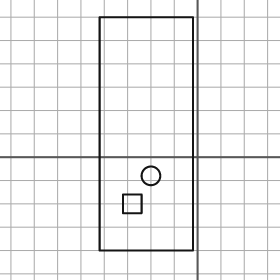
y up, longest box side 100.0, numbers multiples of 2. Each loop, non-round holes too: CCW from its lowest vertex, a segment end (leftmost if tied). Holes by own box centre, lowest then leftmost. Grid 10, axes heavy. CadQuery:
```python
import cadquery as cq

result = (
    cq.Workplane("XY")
    .moveTo(-42.0, -40.0)
    .lineTo(-2.0, -40.0)
    .lineTo(-2.0, 60.0)
    .lineTo(-42.0, 60.0)
    .close()
    .moveTo(-32.0, -24.0)
    .lineTo(-24.0, -24.0)
    .lineTo(-24.0, -16.0)
    .lineTo(-32.0, -16.0)
    .close()
    .moveTo(-20.0, -8.0)
    .circle(4.0)
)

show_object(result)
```